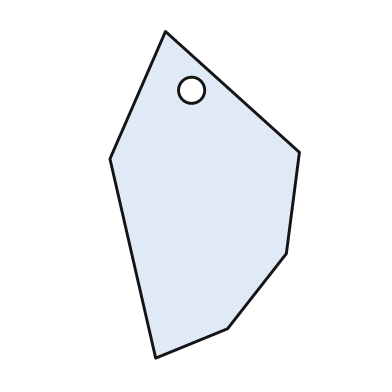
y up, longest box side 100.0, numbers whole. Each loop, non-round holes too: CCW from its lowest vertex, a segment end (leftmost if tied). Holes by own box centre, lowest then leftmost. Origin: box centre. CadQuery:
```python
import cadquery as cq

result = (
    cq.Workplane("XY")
    .moveTo(-15.0, -50.0)
    .lineTo(7.0, -41.0)
    .lineTo(25.0, -18.0)
    .lineTo(29.0, 13.0)
    .lineTo(-12.0, 50.0)
    .lineTo(-29.0, 11.0)
    .close()
    .moveTo(-4.0, 32.0)
    .circle(4.0)
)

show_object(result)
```